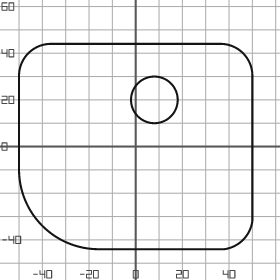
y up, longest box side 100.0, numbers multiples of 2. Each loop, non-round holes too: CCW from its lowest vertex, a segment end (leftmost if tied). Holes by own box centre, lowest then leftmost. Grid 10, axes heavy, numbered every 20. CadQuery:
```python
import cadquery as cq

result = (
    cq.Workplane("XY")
    .moveTo(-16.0, -44.0)
    .lineTo(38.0, -44.0)
    .threePointArc((46.0, -40.0), (50.0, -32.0))
    .lineTo(50.0, 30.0)
    .threePointArc((46.0, 40.0), (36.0, 44.0))
    .lineTo(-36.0, 44.0)
    .threePointArc((-46.0, 40.0), (-50.0, 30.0))
    .lineTo(-50.0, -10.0)
    .threePointArc((-40.0, -34.0), (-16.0, -44.0))
    .close()
    .moveTo(8.0, 20.0)
    .circle(10.0)
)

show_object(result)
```